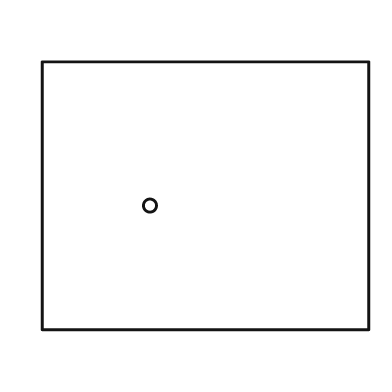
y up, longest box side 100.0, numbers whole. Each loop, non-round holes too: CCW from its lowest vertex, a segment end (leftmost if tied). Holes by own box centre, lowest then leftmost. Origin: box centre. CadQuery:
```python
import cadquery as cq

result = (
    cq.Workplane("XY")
    .moveTo(-50.0, -41.0)
    .lineTo(50.0, -41.0)
    .lineTo(50.0, 41.0)
    .lineTo(-50.0, 41.0)
    .close()
    .moveTo(-17.0, -3.0)
    .circle(2.0)
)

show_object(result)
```